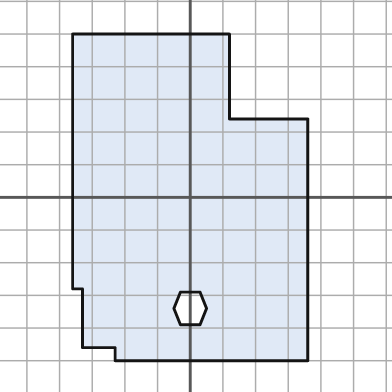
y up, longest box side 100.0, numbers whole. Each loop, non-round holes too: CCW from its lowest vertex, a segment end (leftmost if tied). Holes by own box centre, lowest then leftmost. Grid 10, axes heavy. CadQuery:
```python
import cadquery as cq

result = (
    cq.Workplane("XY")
    .moveTo(-23.0, -50.0)
    .lineTo(36.0, -50.0)
    .lineTo(36.0, 24.0)
    .lineTo(12.0, 24.0)
    .lineTo(12.0, 50.0)
    .lineTo(-36.0, 50.0)
    .lineTo(-36.0, -28.0)
    .lineTo(-33.0, -28.0)
    .lineTo(-33.0, -46.0)
    .lineTo(-23.0, -46.0)
    .close()
    .moveTo(-3.0, -39.0)
    .lineTo(3.0, -39.0)
    .lineTo(5.0, -34.0)
    .lineTo(3.0, -29.0)
    .lineTo(-3.0, -29.0)
    .lineTo(-5.0, -34.0)
    .close()
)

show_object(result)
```